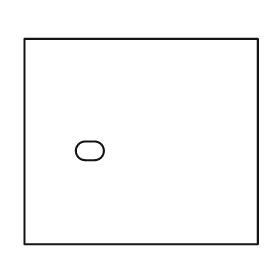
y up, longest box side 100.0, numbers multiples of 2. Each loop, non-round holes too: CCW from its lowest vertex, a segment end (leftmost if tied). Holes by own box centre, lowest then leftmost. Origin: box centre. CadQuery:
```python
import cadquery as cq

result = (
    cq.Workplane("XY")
    .moveTo(-50.0, -44.0)
    .lineTo(50.0, -44.0)
    .lineTo(50.0, 44.0)
    .lineTo(-50.0, 44.0)
    .close()
    .moveTo(-24.0, -8.0)
    .lineTo(-20.0, -8.0)
    .threePointArc((-16.0, -4.0), (-20.0, 0.0))
    .lineTo(-24.0, 0.0)
    .threePointArc((-28.0, -4.0), (-24.0, -8.0))
    .close()
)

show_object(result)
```